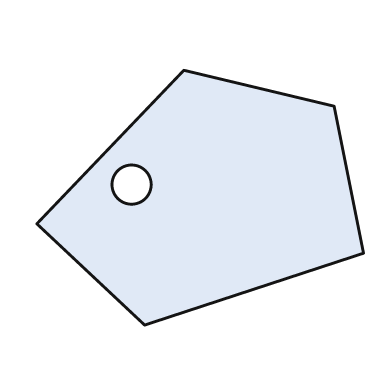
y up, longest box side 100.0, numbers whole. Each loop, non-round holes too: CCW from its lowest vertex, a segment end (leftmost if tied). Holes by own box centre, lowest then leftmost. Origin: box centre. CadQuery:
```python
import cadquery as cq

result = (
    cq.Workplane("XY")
    .moveTo(-17.0, -39.0)
    .lineTo(50.0, -17.0)
    .lineTo(41.0, 28.0)
    .lineTo(-5.0, 39.0)
    .lineTo(-50.0, -8.0)
    .close()
    .moveTo(-21.0, 4.0)
    .circle(6.0)
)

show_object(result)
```